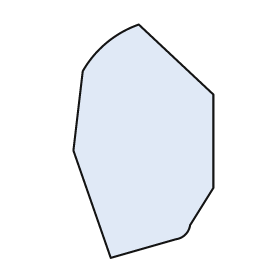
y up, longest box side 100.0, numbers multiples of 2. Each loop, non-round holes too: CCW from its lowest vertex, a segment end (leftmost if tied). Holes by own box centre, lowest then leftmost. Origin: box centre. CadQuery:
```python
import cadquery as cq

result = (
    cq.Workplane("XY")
    .moveTo(-14.0, -50.0)
    .lineTo(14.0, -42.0)
    .threePointArc((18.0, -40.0), (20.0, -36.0))
    .lineTo(30.0, -20.0)
    .lineTo(30.0, 20.0)
    .lineTo(-2.0, 50.0)
    .threePointArc((-16.0, 42.0), (-26.0, 30.0))
    .lineTo(-30.0, -4.0)
    .close()
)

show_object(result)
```